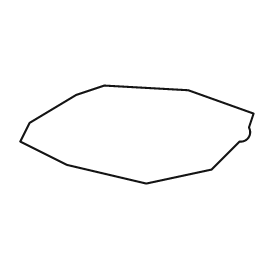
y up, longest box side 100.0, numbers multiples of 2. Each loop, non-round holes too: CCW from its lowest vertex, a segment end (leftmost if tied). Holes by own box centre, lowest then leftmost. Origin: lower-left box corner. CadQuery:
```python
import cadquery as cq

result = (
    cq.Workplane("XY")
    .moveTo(54.0, 0.0)
    .lineTo(82.0, 6.0)
    .lineTo(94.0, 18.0)
    .threePointArc((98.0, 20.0), (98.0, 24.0))
    .lineTo(100.0, 30.0)
    .lineTo(72.0, 40.0)
    .lineTo(36.0, 42.0)
    .lineTo(24.0, 38.0)
    .lineTo(4.0, 26.0)
    .lineTo(0.0, 18.0)
    .lineTo(20.0, 8.0)
    .close()
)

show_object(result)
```